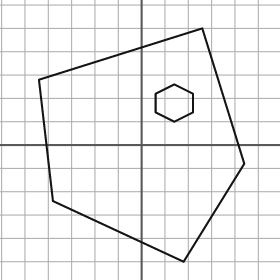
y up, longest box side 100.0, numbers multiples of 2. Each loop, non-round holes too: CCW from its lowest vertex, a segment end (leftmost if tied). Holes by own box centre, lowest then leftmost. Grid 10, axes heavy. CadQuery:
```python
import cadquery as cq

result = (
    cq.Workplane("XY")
    .moveTo(18.0, -50.0)
    .lineTo(44.0, -8.0)
    .lineTo(26.0, 50.0)
    .lineTo(-44.0, 28.0)
    .lineTo(-38.0, -24.0)
    .close()
    .moveTo(14.0, 10.0)
    .lineTo(22.0, 14.0)
    .lineTo(22.0, 22.0)
    .lineTo(14.0, 26.0)
    .lineTo(6.0, 22.0)
    .lineTo(6.0, 14.0)
    .close()
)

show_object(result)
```